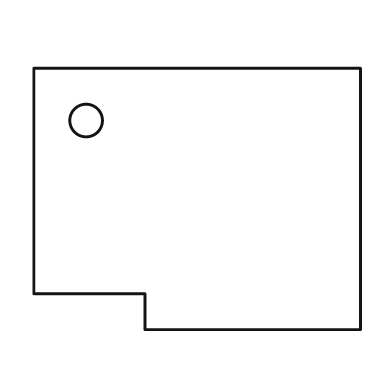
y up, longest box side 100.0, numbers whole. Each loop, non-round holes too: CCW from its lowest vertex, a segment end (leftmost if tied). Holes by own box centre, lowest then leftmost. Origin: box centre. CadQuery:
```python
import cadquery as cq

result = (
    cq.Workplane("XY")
    .moveTo(-16.0, -40.0)
    .lineTo(50.0, -40.0)
    .lineTo(50.0, 40.0)
    .lineTo(-50.0, 40.0)
    .lineTo(-50.0, -29.0)
    .lineTo(-16.0, -29.0)
    .close()
    .moveTo(-34.0, 24.0)
    .circle(5.0)
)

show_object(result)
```